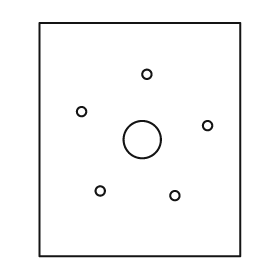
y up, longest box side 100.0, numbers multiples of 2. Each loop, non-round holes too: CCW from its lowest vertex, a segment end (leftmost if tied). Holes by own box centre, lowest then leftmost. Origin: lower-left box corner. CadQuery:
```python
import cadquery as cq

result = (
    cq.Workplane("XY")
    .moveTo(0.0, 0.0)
    .lineTo(86.0, 0.0)
    .lineTo(86.0, 100.0)
    .lineTo(0.0, 100.0)
    .close()
    .moveTo(58.0, 26.0)
    .circle(2.0)
    .moveTo(26.0, 28.0)
    .circle(2.0)
    .moveTo(44.0, 50.0)
    .circle(8.0)
    .moveTo(72.0, 56.0)
    .circle(2.0)
    .moveTo(18.0, 62.0)
    .circle(2.0)
    .moveTo(46.0, 78.0)
    .circle(2.0)
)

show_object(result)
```